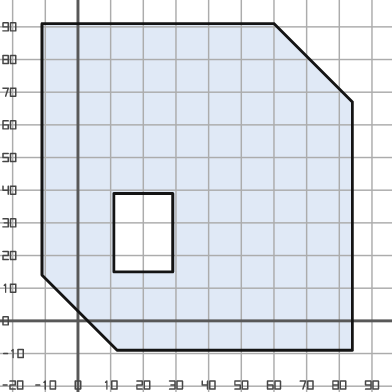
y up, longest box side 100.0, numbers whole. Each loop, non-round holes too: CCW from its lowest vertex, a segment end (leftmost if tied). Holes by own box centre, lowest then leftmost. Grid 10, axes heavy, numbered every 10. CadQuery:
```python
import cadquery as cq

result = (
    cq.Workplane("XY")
    .moveTo(12.0, -9.0)
    .lineTo(84.0, -9.0)
    .lineTo(84.0, 67.0)
    .lineTo(60.0, 91.0)
    .lineTo(-11.0, 91.0)
    .lineTo(-11.0, 14.0)
    .close()
    .moveTo(11.0, 15.0)
    .lineTo(29.0, 15.0)
    .lineTo(29.0, 39.0)
    .lineTo(11.0, 39.0)
    .close()
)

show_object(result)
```